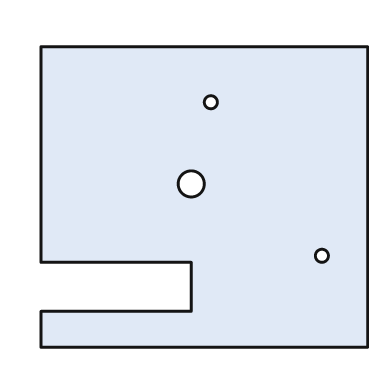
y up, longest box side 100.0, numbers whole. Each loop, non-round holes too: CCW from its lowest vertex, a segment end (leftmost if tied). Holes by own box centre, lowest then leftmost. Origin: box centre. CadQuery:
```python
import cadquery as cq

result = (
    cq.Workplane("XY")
    .moveTo(-50.0, -46.0)
    .lineTo(50.0, -46.0)
    .lineTo(50.0, 46.0)
    .lineTo(-50.0, 46.0)
    .lineTo(-50.0, -20.0)
    .lineTo(-4.0, -20.0)
    .lineTo(-4.0, -35.0)
    .lineTo(-50.0, -35.0)
    .close()
    .moveTo(36.0, -18.0)
    .circle(2.0)
    .moveTo(-4.0, 4.0)
    .circle(4.0)
    .moveTo(2.0, 29.0)
    .circle(2.0)
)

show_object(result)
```